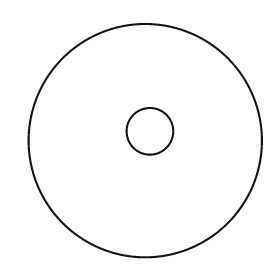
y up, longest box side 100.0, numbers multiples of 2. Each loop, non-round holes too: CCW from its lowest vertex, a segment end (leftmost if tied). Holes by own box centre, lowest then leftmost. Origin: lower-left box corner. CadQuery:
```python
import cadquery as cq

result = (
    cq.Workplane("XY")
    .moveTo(50.0, 50.0)
    .circle(50.0)
    .moveTo(52.0, 54.0)
    .circle(10.0)
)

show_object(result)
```